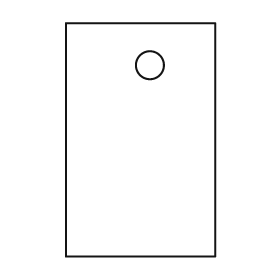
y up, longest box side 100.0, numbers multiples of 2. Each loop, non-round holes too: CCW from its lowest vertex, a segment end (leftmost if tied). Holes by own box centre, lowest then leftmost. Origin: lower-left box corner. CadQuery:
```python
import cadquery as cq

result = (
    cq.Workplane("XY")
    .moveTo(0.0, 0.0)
    .lineTo(64.0, 0.0)
    .lineTo(64.0, 100.0)
    .lineTo(0.0, 100.0)
    .close()
    .moveTo(36.0, 82.0)
    .circle(6.0)
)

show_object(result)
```